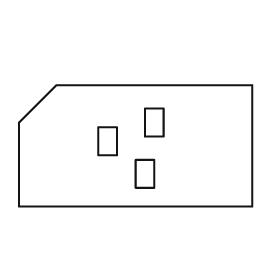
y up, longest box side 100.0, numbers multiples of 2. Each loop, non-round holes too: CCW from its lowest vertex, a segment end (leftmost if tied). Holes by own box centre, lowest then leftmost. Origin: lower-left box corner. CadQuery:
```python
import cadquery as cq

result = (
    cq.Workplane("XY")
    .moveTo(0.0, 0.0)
    .lineTo(100.0, 0.0)
    .lineTo(100.0, 52.0)
    .lineTo(16.0, 52.0)
    .lineTo(0.0, 36.0)
    .close()
    .moveTo(50.0, 8.0)
    .lineTo(58.0, 8.0)
    .lineTo(58.0, 20.0)
    .lineTo(50.0, 20.0)
    .close()
    .moveTo(34.0, 22.0)
    .lineTo(42.0, 22.0)
    .lineTo(42.0, 34.0)
    .lineTo(34.0, 34.0)
    .close()
    .moveTo(54.0, 30.0)
    .lineTo(62.0, 30.0)
    .lineTo(62.0, 42.0)
    .lineTo(54.0, 42.0)
    .close()
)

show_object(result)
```